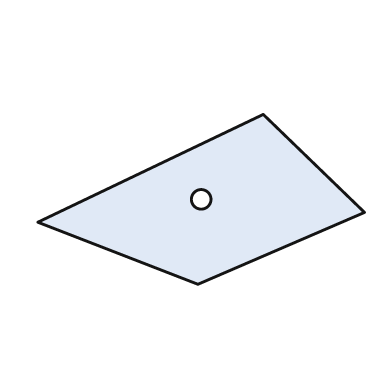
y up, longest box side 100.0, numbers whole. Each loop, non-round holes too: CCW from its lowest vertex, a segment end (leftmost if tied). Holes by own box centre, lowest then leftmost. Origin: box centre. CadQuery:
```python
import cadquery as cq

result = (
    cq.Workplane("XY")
    .moveTo(-1.0, -26.0)
    .lineTo(50.0, -4.0)
    .lineTo(19.0, 26.0)
    .lineTo(-50.0, -7.0)
    .close()
    .moveTo(0.0, 0.0)
    .circle(3.0)
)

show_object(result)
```